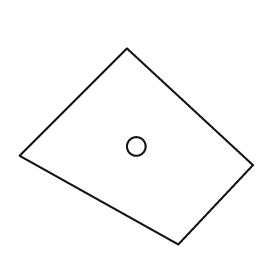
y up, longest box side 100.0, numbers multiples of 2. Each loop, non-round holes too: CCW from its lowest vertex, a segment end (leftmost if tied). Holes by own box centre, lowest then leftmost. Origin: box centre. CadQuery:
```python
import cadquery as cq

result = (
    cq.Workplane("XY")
    .moveTo(18.0, -42.0)
    .lineTo(50.0, -8.0)
    .lineTo(-4.0, 42.0)
    .lineTo(-50.0, -4.0)
    .close()
    .moveTo(0.0, 0.0)
    .circle(4.0)
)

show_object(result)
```